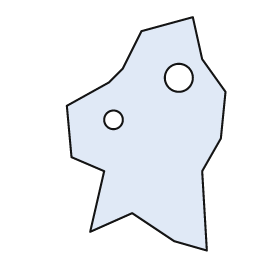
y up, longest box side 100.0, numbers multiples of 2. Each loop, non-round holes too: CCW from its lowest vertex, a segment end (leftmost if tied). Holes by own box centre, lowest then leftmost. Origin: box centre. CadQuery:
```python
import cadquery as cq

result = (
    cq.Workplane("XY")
    .moveTo(26.0, -50.0)
    .lineTo(24.0, -16.0)
    .lineTo(32.0, -2.0)
    .lineTo(34.0, 18.0)
    .lineTo(24.0, 32.0)
    .lineTo(20.0, 50.0)
    .lineTo(-2.0, 44.0)
    .lineTo(-10.0, 28.0)
    .lineTo(-16.0, 22.0)
    .lineTo(-34.0, 12.0)
    .lineTo(-32.0, -10.0)
    .lineTo(-18.0, -16.0)
    .lineTo(-24.0, -42.0)
    .lineTo(-6.0, -34.0)
    .lineTo(12.0, -46.0)
    .close()
    .moveTo(-14.0, 6.0)
    .circle(4.0)
    .moveTo(14.0, 24.0)
    .circle(6.0)
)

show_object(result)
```